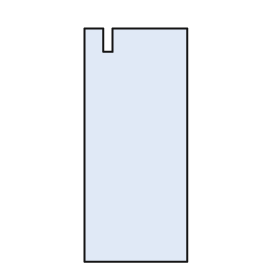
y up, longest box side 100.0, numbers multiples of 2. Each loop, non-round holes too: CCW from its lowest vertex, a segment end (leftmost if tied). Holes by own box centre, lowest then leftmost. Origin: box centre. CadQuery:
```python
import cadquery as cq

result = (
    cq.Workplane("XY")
    .moveTo(-22.0, -50.0)
    .lineTo(22.0, -50.0)
    .lineTo(22.0, 50.0)
    .lineTo(-10.0, 50.0)
    .lineTo(-10.0, 40.0)
    .lineTo(-14.0, 40.0)
    .lineTo(-14.0, 50.0)
    .lineTo(-22.0, 50.0)
    .close()
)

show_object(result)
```